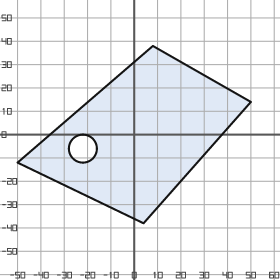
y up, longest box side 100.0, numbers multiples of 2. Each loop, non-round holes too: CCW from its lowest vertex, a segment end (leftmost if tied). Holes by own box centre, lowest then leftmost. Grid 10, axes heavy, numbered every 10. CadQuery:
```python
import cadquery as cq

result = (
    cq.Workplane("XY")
    .moveTo(4.0, -38.0)
    .lineTo(50.0, 14.0)
    .lineTo(8.0, 38.0)
    .lineTo(-50.0, -12.0)
    .close()
    .moveTo(-22.0, -6.0)
    .circle(6.0)
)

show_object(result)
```